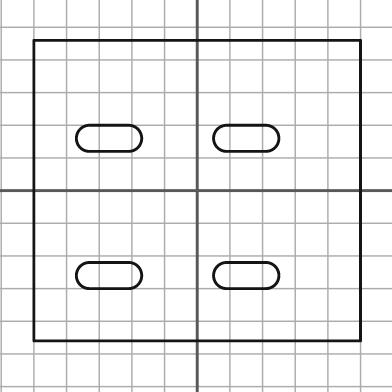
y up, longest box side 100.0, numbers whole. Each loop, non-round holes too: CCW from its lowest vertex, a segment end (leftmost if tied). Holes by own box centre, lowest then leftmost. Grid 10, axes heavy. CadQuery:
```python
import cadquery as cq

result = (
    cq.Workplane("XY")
    .moveTo(-50.0, -46.0)
    .lineTo(50.0, -46.0)
    .lineTo(50.0, 46.0)
    .lineTo(-50.0, 46.0)
    .close()
    .moveTo(-33.0, -30.0)
    .lineTo(-21.0, -30.0)
    .threePointArc((-17.0, -26.0), (-21.0, -22.0))
    .lineTo(-33.0, -22.0)
    .threePointArc((-37.0, -26.0), (-33.0, -30.0))
    .close()
    .moveTo(9.0, -30.0)
    .lineTo(21.0, -30.0)
    .threePointArc((25.0, -26.0), (21.0, -22.0))
    .lineTo(9.0, -22.0)
    .threePointArc((5.0, -26.0), (9.0, -30.0))
    .close()
    .moveTo(-33.0, 12.0)
    .lineTo(-21.0, 12.0)
    .threePointArc((-17.0, 16.0), (-21.0, 20.0))
    .lineTo(-33.0, 20.0)
    .threePointArc((-37.0, 16.0), (-33.0, 12.0))
    .close()
    .moveTo(9.0, 12.0)
    .lineTo(21.0, 12.0)
    .threePointArc((25.0, 16.0), (21.0, 20.0))
    .lineTo(9.0, 20.0)
    .threePointArc((5.0, 16.0), (9.0, 12.0))
    .close()
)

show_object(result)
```